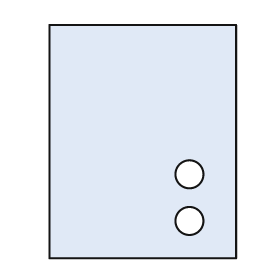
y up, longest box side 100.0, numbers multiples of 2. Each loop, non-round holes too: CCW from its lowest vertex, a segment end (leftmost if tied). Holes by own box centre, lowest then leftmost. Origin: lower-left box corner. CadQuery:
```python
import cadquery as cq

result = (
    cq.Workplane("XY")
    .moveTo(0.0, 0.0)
    .lineTo(80.0, 0.0)
    .lineTo(80.0, 100.0)
    .lineTo(0.0, 100.0)
    .close()
    .moveTo(60.0, 16.0)
    .circle(6.0)
    .moveTo(60.0, 36.0)
    .circle(6.0)
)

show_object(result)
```